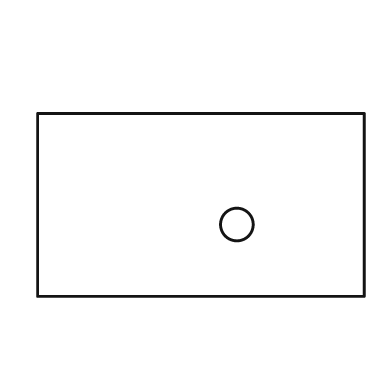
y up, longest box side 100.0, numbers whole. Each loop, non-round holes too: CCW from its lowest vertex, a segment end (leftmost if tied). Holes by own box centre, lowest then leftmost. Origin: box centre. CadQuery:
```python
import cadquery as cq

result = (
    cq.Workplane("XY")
    .moveTo(-50.0, -28.0)
    .lineTo(50.0, -28.0)
    .lineTo(50.0, 28.0)
    .lineTo(-50.0, 28.0)
    .close()
    .moveTo(11.0, -6.0)
    .circle(5.0)
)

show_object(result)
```